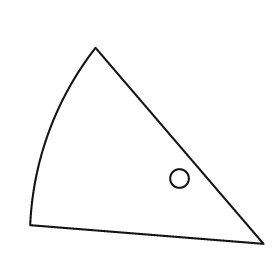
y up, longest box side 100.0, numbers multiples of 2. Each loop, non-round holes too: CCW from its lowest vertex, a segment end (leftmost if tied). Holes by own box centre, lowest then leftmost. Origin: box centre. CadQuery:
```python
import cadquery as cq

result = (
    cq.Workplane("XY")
    .moveTo(50.0, -42.0)
    .lineTo(-22.0, 42.0)
    .threePointArc((-42.0, 6.0), (-50.0, -34.0))
    .close()
    .moveTo(14.0, -14.0)
    .circle(4.0)
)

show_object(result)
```